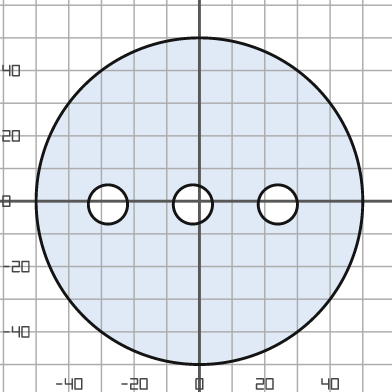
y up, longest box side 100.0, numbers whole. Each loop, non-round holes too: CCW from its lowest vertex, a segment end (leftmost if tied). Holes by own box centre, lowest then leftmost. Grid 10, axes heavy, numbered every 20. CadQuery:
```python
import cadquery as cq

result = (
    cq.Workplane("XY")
    .moveTo(0.0, 0.0)
    .circle(50.0)
    .moveTo(-28.0, -1.0)
    .circle(6.0)
    .moveTo(-2.0, -1.0)
    .circle(6.0)
    .moveTo(24.0, -1.0)
    .circle(6.0)
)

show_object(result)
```